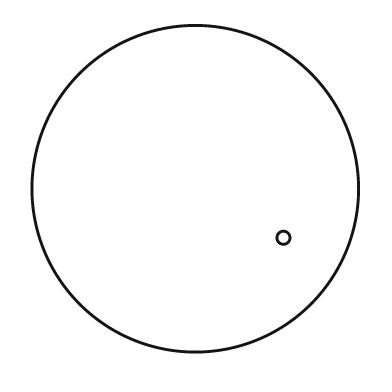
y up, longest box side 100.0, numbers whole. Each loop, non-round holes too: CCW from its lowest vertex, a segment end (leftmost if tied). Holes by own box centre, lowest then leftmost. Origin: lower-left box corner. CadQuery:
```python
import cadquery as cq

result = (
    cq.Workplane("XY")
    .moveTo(50.0, 50.0)
    .circle(50.0)
    .moveTo(77.0, 35.0)
    .circle(2.0)
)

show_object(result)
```